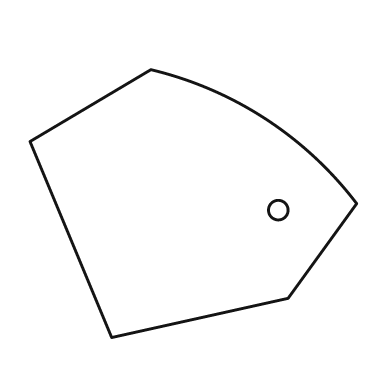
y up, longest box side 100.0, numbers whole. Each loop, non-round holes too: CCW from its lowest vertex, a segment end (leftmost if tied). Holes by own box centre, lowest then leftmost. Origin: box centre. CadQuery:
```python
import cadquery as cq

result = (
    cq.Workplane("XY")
    .moveTo(-25.0, -41.0)
    .lineTo(29.0, -29.0)
    .lineTo(50.0, 0.0)
    .threePointArc((22.0, 26.0), (-13.0, 41.0))
    .lineTo(-50.0, 19.0)
    .close()
    .moveTo(26.0, -2.0)
    .circle(3.0)
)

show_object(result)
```